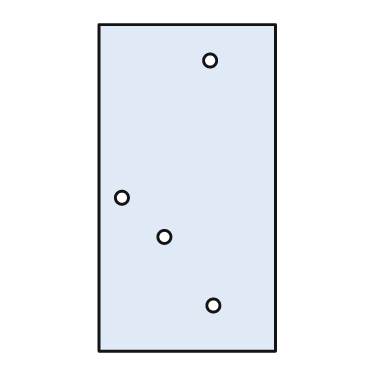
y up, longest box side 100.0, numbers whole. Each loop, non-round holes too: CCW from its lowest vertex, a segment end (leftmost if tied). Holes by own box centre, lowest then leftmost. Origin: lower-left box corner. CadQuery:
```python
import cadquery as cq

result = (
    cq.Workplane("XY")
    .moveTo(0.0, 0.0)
    .lineTo(54.0, 0.0)
    .lineTo(54.0, 100.0)
    .lineTo(0.0, 100.0)
    .close()
    .moveTo(35.0, 14.0)
    .circle(2.0)
    .moveTo(20.0, 35.0)
    .circle(2.0)
    .moveTo(7.0, 47.0)
    .circle(2.0)
    .moveTo(34.0, 89.0)
    .circle(2.0)
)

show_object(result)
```